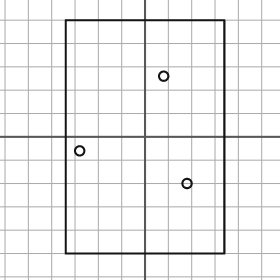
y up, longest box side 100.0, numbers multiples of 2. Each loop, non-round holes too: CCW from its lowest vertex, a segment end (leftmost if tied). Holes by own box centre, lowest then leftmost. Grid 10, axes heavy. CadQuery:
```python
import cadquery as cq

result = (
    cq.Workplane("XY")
    .moveTo(-34.0, -50.0)
    .lineTo(34.0, -50.0)
    .lineTo(34.0, 50.0)
    .lineTo(-34.0, 50.0)
    .close()
    .moveTo(18.0, -20.0)
    .circle(2.0)
    .moveTo(-28.0, -6.0)
    .circle(2.0)
    .moveTo(8.0, 26.0)
    .circle(2.0)
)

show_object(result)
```